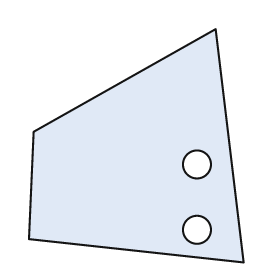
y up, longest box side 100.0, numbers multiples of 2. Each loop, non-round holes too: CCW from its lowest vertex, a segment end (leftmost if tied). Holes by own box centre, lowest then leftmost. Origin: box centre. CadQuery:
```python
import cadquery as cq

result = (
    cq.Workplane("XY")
    .moveTo(46.0, -50.0)
    .lineTo(34.0, 50.0)
    .lineTo(-44.0, 6.0)
    .lineTo(-46.0, -40.0)
    .close()
    .moveTo(26.0, -36.0)
    .circle(6.0)
    .moveTo(26.0, -8.0)
    .circle(6.0)
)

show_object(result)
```